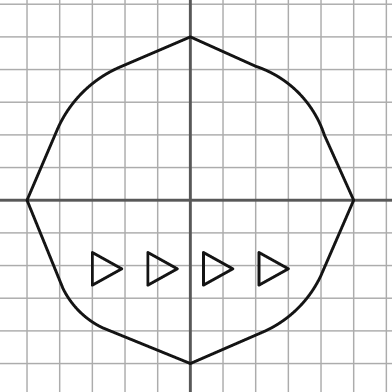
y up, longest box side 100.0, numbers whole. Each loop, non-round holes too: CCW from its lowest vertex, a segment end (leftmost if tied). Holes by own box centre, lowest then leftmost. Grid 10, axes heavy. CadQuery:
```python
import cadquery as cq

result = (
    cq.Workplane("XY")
    .moveTo(0.0, -50.0)
    .lineTo(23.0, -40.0)
    .threePointArc((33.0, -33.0), (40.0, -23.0))
    .lineTo(50.0, 0.0)
    .lineTo(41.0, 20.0)
    .threePointArc((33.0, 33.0), (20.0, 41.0))
    .lineTo(0.0, 50.0)
    .lineTo(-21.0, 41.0)
    .threePointArc((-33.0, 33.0), (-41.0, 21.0))
    .lineTo(-50.0, 0.0)
    .lineTo(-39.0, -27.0)
    .threePointArc((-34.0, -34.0), (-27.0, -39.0))
    .close()
    .moveTo(-30.0, -26.0)
    .lineTo(-21.0, -21.0)
    .lineTo(-30.0, -16.0)
    .close()
    .moveTo(-13.0, -26.0)
    .lineTo(-4.0, -21.0)
    .lineTo(-13.0, -16.0)
    .close()
    .moveTo(4.0, -26.0)
    .lineTo(13.0, -21.0)
    .lineTo(4.0, -16.0)
    .close()
    .moveTo(21.0, -26.0)
    .lineTo(30.0, -21.0)
    .lineTo(21.0, -16.0)
    .close()
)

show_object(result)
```